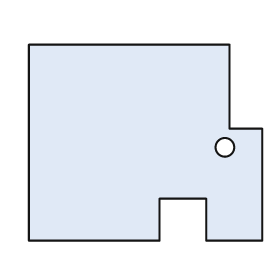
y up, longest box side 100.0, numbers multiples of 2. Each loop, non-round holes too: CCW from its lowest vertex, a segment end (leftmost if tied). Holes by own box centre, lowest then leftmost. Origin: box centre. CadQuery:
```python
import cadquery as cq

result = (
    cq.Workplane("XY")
    .moveTo(-50.0, -42.0)
    .lineTo(6.0, -42.0)
    .lineTo(6.0, -24.0)
    .lineTo(26.0, -24.0)
    .lineTo(26.0, -42.0)
    .lineTo(50.0, -42.0)
    .lineTo(50.0, 6.0)
    .lineTo(36.0, 6.0)
    .lineTo(36.0, 42.0)
    .lineTo(-50.0, 42.0)
    .close()
    .moveTo(34.0, -2.0)
    .circle(4.0)
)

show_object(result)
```